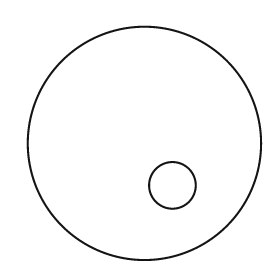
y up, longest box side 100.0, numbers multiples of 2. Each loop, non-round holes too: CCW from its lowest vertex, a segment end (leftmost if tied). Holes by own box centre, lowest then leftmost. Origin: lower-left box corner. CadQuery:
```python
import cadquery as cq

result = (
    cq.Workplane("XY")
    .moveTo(50.0, 50.0)
    .circle(50.0)
    .moveTo(62.0, 32.0)
    .circle(10.0)
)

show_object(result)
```